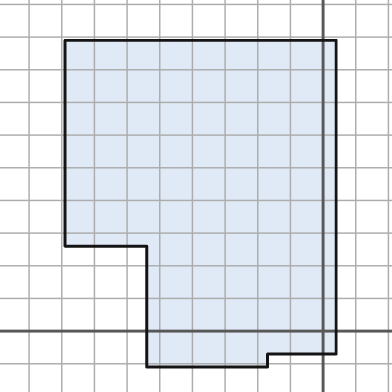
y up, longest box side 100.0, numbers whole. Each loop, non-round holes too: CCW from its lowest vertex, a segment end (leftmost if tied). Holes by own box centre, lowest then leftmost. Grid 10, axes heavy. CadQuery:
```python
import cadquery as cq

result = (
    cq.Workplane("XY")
    .moveTo(-54.0, -11.0)
    .lineTo(-17.0, -11.0)
    .lineTo(-17.0, -7.0)
    .lineTo(4.0, -7.0)
    .lineTo(4.0, 89.0)
    .lineTo(-79.0, 89.0)
    .lineTo(-79.0, 26.0)
    .lineTo(-54.0, 26.0)
    .close()
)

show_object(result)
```